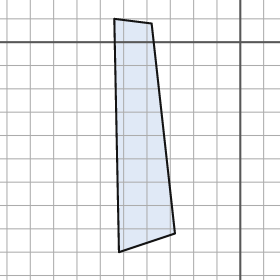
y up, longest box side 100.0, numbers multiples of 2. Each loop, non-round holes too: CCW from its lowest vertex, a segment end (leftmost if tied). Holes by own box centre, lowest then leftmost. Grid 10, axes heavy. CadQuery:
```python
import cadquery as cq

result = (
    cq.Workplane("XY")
    .moveTo(-52.0, -90.0)
    .lineTo(-28.0, -82.0)
    .lineTo(-38.0, 8.0)
    .lineTo(-54.0, 10.0)
    .close()
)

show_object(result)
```